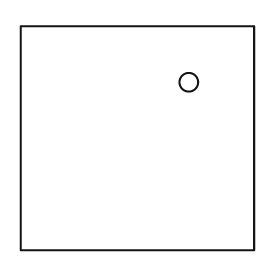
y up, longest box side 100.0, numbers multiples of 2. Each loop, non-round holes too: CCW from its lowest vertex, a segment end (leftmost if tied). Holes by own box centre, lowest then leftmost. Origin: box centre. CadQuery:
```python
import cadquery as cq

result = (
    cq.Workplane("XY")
    .moveTo(-50.0, -48.0)
    .lineTo(50.0, -48.0)
    .lineTo(50.0, 48.0)
    .lineTo(-50.0, 48.0)
    .close()
    .moveTo(22.0, 24.0)
    .circle(4.0)
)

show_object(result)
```